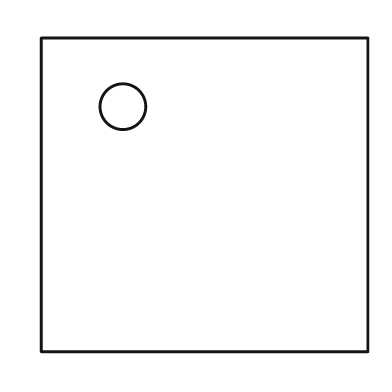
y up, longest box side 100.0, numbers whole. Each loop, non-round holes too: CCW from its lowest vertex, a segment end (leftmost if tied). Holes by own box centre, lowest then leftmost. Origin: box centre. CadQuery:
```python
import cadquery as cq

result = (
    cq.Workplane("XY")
    .moveTo(-50.0, -48.0)
    .lineTo(50.0, -48.0)
    .lineTo(50.0, 48.0)
    .lineTo(-50.0, 48.0)
    .close()
    .moveTo(-25.0, 27.0)
    .circle(7.0)
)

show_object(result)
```